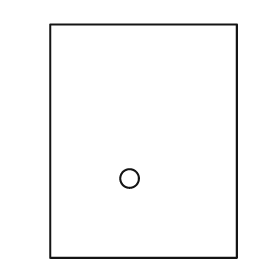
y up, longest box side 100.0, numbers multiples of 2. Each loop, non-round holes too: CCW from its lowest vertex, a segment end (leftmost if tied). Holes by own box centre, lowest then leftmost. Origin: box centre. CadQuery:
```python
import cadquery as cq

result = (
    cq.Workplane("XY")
    .moveTo(-40.0, -50.0)
    .lineTo(40.0, -50.0)
    .lineTo(40.0, 50.0)
    .lineTo(-40.0, 50.0)
    .close()
    .moveTo(-6.0, -16.0)
    .circle(4.0)
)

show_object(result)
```